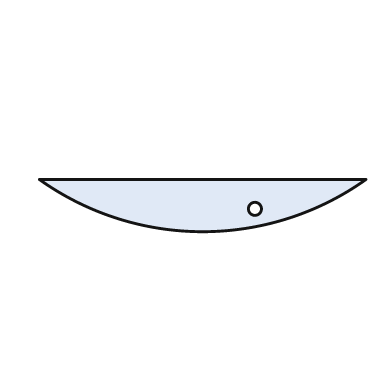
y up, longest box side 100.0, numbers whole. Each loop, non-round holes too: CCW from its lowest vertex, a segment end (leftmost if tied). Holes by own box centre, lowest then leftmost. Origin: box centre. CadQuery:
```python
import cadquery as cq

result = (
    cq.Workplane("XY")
    .moveTo(-50.0, 8.0)
    .threePointArc((0.0, -8.0), (50.0, 8.0))
    .close()
    .moveTo(16.0, -1.0)
    .circle(2.0)
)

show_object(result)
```